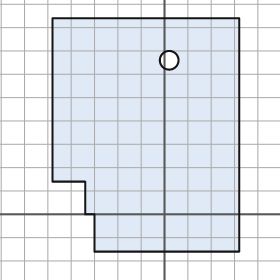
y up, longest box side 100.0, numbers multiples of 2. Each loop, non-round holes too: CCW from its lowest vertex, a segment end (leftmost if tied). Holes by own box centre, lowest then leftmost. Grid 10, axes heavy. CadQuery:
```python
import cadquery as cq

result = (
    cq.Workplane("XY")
    .moveTo(-30.0, -16.0)
    .lineTo(32.0, -16.0)
    .lineTo(32.0, 84.0)
    .lineTo(-48.0, 84.0)
    .lineTo(-48.0, 14.0)
    .lineTo(-34.0, 14.0)
    .lineTo(-34.0, 0.0)
    .lineTo(-30.0, 0.0)
    .close()
    .moveTo(2.0, 66.0)
    .circle(4.0)
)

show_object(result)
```